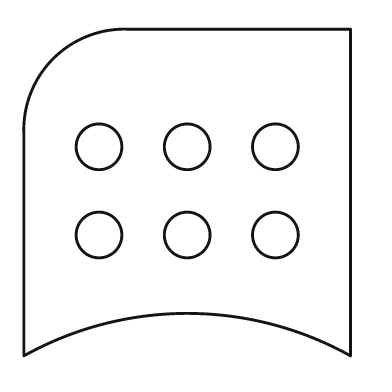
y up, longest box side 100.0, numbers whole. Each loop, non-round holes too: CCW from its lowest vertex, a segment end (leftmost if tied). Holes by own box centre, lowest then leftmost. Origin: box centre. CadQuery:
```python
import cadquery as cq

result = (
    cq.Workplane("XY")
    .moveTo(-50.0, -50.0)
    .threePointArc((0.0, -37.0), (50.0, -50.0))
    .lineTo(50.0, 50.0)
    .lineTo(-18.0, 50.0)
    .threePointArc((-41.0, 41.0), (-50.0, 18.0))
    .close()
    .moveTo(-27.0, -13.0)
    .circle(7.0)
    .moveTo(0.0, -13.0)
    .circle(7.0)
    .moveTo(27.0, -13.0)
    .circle(7.0)
    .moveTo(-27.0, 14.0)
    .circle(7.0)
    .moveTo(0.0, 14.0)
    .circle(7.0)
    .moveTo(27.0, 14.0)
    .circle(7.0)
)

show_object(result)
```